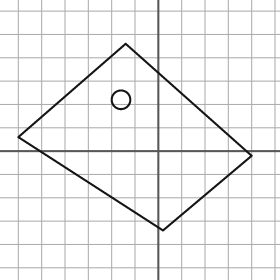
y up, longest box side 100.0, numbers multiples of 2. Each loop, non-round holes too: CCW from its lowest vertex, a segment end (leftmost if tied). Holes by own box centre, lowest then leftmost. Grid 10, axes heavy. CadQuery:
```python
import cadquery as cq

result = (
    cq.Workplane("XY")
    .moveTo(2.0, -34.0)
    .lineTo(40.0, -2.0)
    .lineTo(-14.0, 46.0)
    .lineTo(-60.0, 6.0)
    .close()
    .moveTo(-16.0, 22.0)
    .circle(4.0)
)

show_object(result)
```